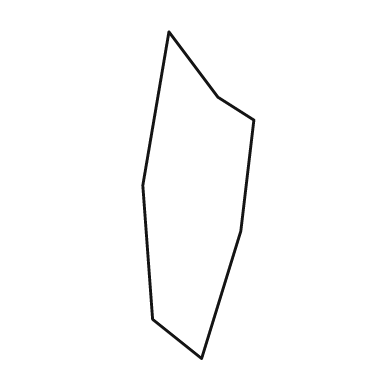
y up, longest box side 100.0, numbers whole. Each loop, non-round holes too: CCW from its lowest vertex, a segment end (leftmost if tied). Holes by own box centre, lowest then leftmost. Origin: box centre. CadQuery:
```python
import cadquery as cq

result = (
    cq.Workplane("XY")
    .moveTo(1.0, -50.0)
    .lineTo(13.0, -11.0)
    .lineTo(17.0, 23.0)
    .lineTo(6.0, 30.0)
    .lineTo(-9.0, 50.0)
    .lineTo(-17.0, 3.0)
    .lineTo(-14.0, -38.0)
    .close()
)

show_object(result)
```